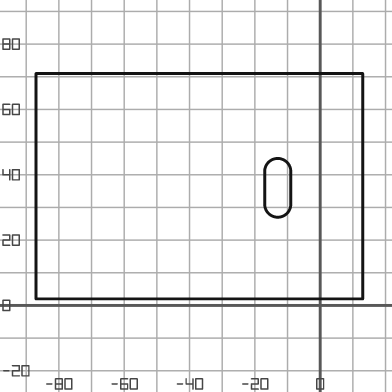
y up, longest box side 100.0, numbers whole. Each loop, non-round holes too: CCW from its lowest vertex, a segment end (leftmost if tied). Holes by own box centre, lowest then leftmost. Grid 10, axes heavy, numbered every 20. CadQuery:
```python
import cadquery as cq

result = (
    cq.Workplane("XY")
    .moveTo(-87.0, 2.0)
    .lineTo(13.0, 2.0)
    .lineTo(13.0, 71.0)
    .lineTo(-87.0, 71.0)
    .close()
    .moveTo(-17.0, 31.0)
    .threePointArc((-13.0, 27.0), (-9.0, 31.0))
    .lineTo(-9.0, 41.0)
    .threePointArc((-13.0, 45.0), (-17.0, 41.0))
    .close()
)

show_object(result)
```